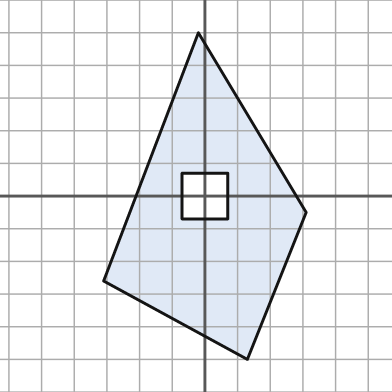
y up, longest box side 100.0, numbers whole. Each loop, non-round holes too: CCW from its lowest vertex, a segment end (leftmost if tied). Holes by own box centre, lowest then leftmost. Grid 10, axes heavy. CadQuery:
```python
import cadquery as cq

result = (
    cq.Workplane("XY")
    .moveTo(13.0, -50.0)
    .lineTo(31.0, -5.0)
    .lineTo(-2.0, 50.0)
    .lineTo(-31.0, -26.0)
    .close()
    .moveTo(-7.0, -7.0)
    .lineTo(7.0, -7.0)
    .lineTo(7.0, 7.0)
    .lineTo(-7.0, 7.0)
    .close()
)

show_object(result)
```